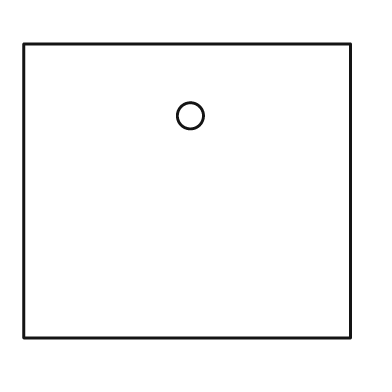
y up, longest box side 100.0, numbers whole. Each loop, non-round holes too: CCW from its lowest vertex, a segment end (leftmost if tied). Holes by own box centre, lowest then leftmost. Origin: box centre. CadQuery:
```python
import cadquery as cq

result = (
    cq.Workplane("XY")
    .moveTo(-50.0, -45.0)
    .lineTo(50.0, -45.0)
    .lineTo(50.0, 45.0)
    .lineTo(-50.0, 45.0)
    .close()
    .moveTo(1.0, 23.0)
    .circle(4.0)
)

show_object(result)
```